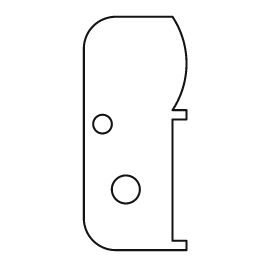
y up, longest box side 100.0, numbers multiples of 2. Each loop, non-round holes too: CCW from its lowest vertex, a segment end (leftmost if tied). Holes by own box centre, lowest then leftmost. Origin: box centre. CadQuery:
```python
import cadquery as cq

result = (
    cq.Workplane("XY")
    .moveTo(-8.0, -50.0)
    .lineTo(22.0, -50.0)
    .lineTo(22.0, -46.0)
    .lineTo(16.0, -46.0)
    .lineTo(16.0, 6.0)
    .lineTo(22.0, 6.0)
    .lineTo(22.0, 10.0)
    .lineTo(16.0, 10.0)
    .threePointArc((22.0, 30.0), (16.0, 50.0))
    .lineTo(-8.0, 50.0)
    .threePointArc((-18.0, 46.0), (-22.0, 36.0))
    .lineTo(-22.0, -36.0)
    .threePointArc((-18.0, -46.0), (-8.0, -50.0))
    .close()
    .moveTo(-4.0, -24.0)
    .circle(6.0)
    .moveTo(-14.0, 4.0)
    .circle(4.0)
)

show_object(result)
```